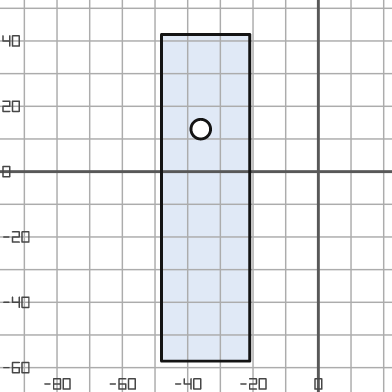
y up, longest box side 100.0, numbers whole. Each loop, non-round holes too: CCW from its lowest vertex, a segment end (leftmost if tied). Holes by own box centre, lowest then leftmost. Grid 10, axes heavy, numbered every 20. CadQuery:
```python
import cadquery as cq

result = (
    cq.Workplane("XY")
    .moveTo(-48.0, -58.0)
    .lineTo(-21.0, -58.0)
    .lineTo(-21.0, 42.0)
    .lineTo(-48.0, 42.0)
    .close()
    .moveTo(-36.0, 13.0)
    .circle(3.0)
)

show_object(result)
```